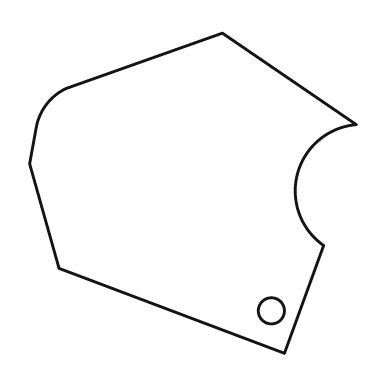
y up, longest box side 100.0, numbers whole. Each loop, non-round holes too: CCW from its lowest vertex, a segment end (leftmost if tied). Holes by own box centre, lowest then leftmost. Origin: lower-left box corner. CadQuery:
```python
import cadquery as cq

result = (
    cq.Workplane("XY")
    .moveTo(78.0, 0.0)
    .lineTo(90.0, 33.0)
    .threePointArc((82.0, 55.0), (100.0, 70.0))
    .lineTo(59.0, 98.0)
    .lineTo(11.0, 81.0)
    .threePointArc((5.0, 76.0), (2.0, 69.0))
    .lineTo(0.0, 58.0)
    .lineTo(9.0, 26.0)
    .close()
    .moveTo(74.0, 13.0)
    .circle(4.0)
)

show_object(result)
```